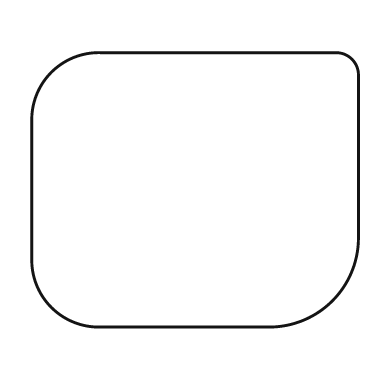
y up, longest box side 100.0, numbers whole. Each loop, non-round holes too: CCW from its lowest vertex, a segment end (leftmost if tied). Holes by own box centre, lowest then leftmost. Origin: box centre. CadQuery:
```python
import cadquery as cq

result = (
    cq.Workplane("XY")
    .moveTo(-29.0, -42.0)
    .lineTo(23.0, -42.0)
    .threePointArc((42.0, -34.0), (50.0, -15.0))
    .lineTo(50.0, 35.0)
    .threePointArc((48.0, 40.0), (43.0, 42.0))
    .lineTo(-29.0, 42.0)
    .threePointArc((-44.0, 36.0), (-50.0, 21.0))
    .lineTo(-50.0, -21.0)
    .threePointArc((-44.0, -36.0), (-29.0, -42.0))
    .close()
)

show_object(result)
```